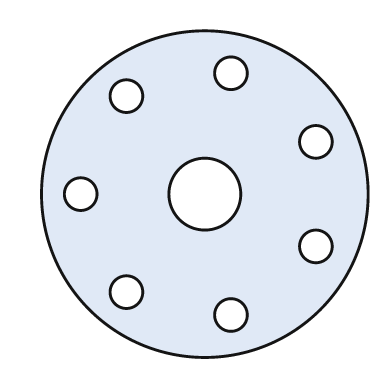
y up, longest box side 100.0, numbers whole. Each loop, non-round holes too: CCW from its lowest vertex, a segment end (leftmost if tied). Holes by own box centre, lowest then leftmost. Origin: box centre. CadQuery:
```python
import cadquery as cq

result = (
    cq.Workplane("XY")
    .moveTo(0.0, 0.0)
    .circle(50.0)
    .moveTo(8.0, -37.0)
    .circle(5.0)
    .moveTo(-24.0, -30.0)
    .circle(5.0)
    .moveTo(34.0, -16.0)
    .circle(5.0)
    .moveTo(-38.0, 0.0)
    .circle(5.0)
    .moveTo(0.0, 0.0)
    .circle(11.0)
    .moveTo(34.0, 16.0)
    .circle(5.0)
    .moveTo(-24.0, 30.0)
    .circle(5.0)
    .moveTo(8.0, 37.0)
    .circle(5.0)
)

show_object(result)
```